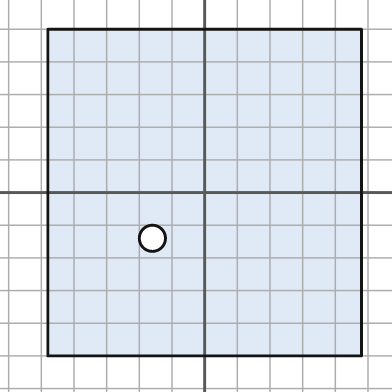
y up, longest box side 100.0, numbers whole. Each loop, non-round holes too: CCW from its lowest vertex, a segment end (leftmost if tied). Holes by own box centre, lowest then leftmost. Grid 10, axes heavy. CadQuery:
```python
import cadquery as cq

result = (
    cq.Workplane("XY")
    .moveTo(-48.0, -50.0)
    .lineTo(48.0, -50.0)
    .lineTo(48.0, 50.0)
    .lineTo(-48.0, 50.0)
    .close()
    .moveTo(-16.0, -14.0)
    .circle(4.0)
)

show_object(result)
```